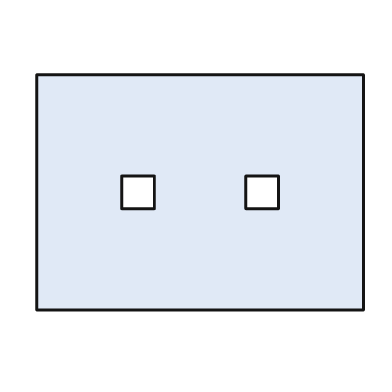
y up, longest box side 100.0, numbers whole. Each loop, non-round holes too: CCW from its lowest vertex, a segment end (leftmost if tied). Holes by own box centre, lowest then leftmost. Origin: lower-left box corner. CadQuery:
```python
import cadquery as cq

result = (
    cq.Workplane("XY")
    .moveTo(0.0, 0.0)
    .lineTo(100.0, 0.0)
    .lineTo(100.0, 72.0)
    .lineTo(0.0, 72.0)
    .close()
    .moveTo(26.0, 31.0)
    .lineTo(36.0, 31.0)
    .lineTo(36.0, 41.0)
    .lineTo(26.0, 41.0)
    .close()
    .moveTo(64.0, 31.0)
    .lineTo(74.0, 31.0)
    .lineTo(74.0, 41.0)
    .lineTo(64.0, 41.0)
    .close()
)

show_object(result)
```